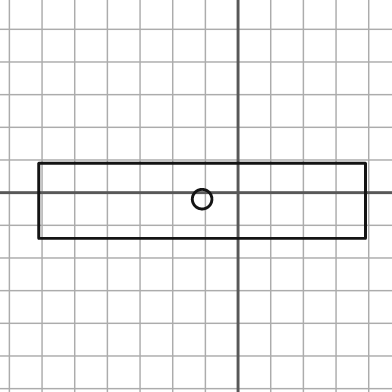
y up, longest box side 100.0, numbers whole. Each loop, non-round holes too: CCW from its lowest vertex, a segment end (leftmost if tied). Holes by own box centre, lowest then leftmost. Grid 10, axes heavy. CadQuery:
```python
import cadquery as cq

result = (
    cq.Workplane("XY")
    .moveTo(-61.0, -14.0)
    .lineTo(39.0, -14.0)
    .lineTo(39.0, 9.0)
    .lineTo(-61.0, 9.0)
    .close()
    .moveTo(-11.0, -2.0)
    .circle(3.0)
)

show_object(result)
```